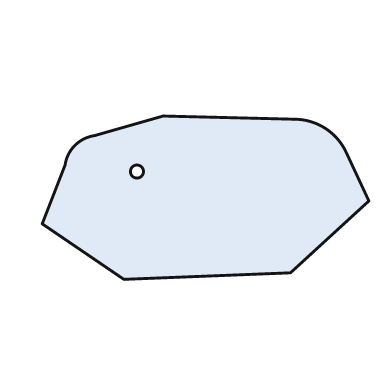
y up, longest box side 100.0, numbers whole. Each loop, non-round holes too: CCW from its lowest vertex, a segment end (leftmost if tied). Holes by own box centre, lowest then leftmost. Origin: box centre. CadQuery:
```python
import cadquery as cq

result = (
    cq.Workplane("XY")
    .moveTo(-25.0, -25.0)
    .lineTo(26.0, -23.0)
    .lineTo(50.0, -1.0)
    .lineTo(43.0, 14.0)
    .threePointArc((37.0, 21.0), (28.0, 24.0))
    .lineTo(-13.0, 25.0)
    .lineTo(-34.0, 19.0)
    .threePointArc((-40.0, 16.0), (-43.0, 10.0))
    .lineTo(-50.0, -8.0)
    .close()
    .moveTo(-21.0, 8.0)
    .circle(2.0)
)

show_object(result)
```